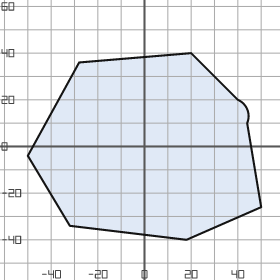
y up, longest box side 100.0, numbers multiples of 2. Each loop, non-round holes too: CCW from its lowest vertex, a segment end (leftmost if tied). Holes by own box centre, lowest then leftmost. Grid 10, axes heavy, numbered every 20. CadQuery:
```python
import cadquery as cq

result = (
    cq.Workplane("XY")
    .moveTo(18.0, -40.0)
    .lineTo(50.0, -26.0)
    .lineTo(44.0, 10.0)
    .threePointArc((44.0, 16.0), (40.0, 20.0))
    .lineTo(20.0, 40.0)
    .lineTo(-28.0, 36.0)
    .lineTo(-50.0, -4.0)
    .lineTo(-32.0, -34.0)
    .close()
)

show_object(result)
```